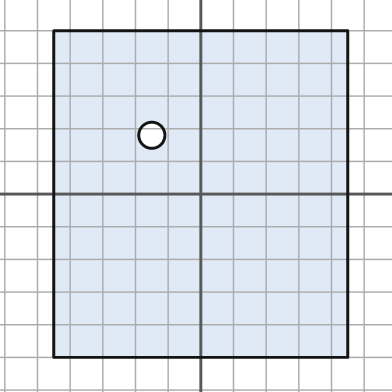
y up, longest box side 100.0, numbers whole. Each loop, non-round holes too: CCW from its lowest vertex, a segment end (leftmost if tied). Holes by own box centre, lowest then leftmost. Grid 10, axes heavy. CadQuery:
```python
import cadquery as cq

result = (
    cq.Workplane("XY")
    .moveTo(-45.0, -50.0)
    .lineTo(45.0, -50.0)
    .lineTo(45.0, 50.0)
    .lineTo(-45.0, 50.0)
    .close()
    .moveTo(-15.0, 18.0)
    .circle(4.0)
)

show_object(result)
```